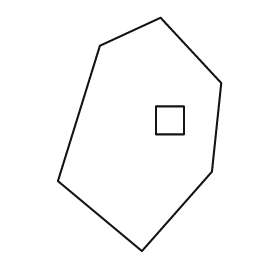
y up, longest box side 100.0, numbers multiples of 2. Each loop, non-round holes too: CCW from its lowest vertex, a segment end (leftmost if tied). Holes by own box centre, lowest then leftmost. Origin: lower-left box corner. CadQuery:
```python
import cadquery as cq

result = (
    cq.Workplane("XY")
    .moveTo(36.0, 0.0)
    .lineTo(66.0, 34.0)
    .lineTo(70.0, 72.0)
    .lineTo(44.0, 100.0)
    .lineTo(18.0, 88.0)
    .lineTo(0.0, 30.0)
    .close()
    .moveTo(42.0, 50.0)
    .lineTo(54.0, 50.0)
    .lineTo(54.0, 62.0)
    .lineTo(42.0, 62.0)
    .close()
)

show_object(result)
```